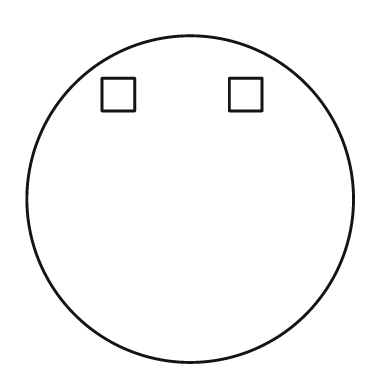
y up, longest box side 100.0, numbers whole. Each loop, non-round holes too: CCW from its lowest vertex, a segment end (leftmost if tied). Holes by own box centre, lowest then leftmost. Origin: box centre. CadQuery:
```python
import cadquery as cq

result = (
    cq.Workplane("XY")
    .moveTo(0.0, 0.0)
    .circle(50.0)
    .moveTo(-27.0, 27.0)
    .lineTo(-17.0, 27.0)
    .lineTo(-17.0, 37.0)
    .lineTo(-27.0, 37.0)
    .close()
    .moveTo(12.0, 27.0)
    .lineTo(22.0, 27.0)
    .lineTo(22.0, 37.0)
    .lineTo(12.0, 37.0)
    .close()
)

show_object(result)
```